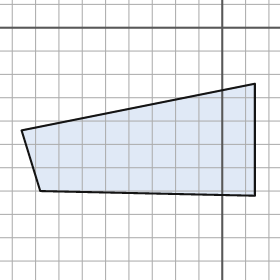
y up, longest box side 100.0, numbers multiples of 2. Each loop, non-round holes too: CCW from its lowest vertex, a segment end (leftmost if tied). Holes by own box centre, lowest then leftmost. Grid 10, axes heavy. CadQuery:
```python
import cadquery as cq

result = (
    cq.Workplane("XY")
    .moveTo(14.0, -72.0)
    .lineTo(14.0, -24.0)
    .lineTo(-86.0, -44.0)
    .lineTo(-78.0, -70.0)
    .close()
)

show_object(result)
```